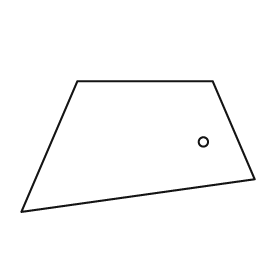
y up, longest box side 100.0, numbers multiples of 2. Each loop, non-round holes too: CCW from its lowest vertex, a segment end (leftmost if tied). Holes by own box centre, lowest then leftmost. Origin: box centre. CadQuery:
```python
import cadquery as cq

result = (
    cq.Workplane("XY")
    .moveTo(-50.0, -28.0)
    .lineTo(50.0, -14.0)
    .lineTo(32.0, 28.0)
    .lineTo(-26.0, 28.0)
    .close()
    .moveTo(28.0, 2.0)
    .circle(2.0)
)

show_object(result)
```